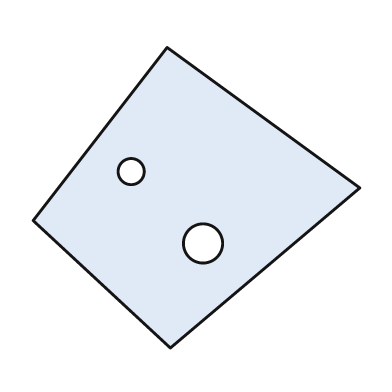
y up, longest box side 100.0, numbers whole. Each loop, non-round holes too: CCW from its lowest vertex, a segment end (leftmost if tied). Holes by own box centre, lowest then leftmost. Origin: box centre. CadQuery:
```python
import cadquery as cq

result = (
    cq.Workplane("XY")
    .moveTo(-8.0, -46.0)
    .lineTo(50.0, 3.0)
    .lineTo(-9.0, 46.0)
    .lineTo(-50.0, -7.0)
    .close()
    .moveTo(2.0, -14.0)
    .circle(6.0)
    .moveTo(-20.0, 8.0)
    .circle(4.0)
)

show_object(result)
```